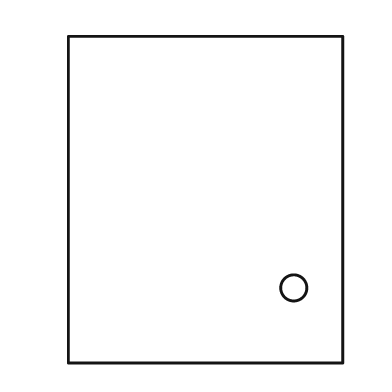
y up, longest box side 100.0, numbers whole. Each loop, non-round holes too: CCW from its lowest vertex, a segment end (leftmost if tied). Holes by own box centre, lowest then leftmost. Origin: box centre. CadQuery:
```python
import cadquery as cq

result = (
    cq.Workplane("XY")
    .moveTo(-42.0, -50.0)
    .lineTo(42.0, -50.0)
    .lineTo(42.0, 50.0)
    .lineTo(-42.0, 50.0)
    .close()
    .moveTo(27.0, -27.0)
    .circle(4.0)
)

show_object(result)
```